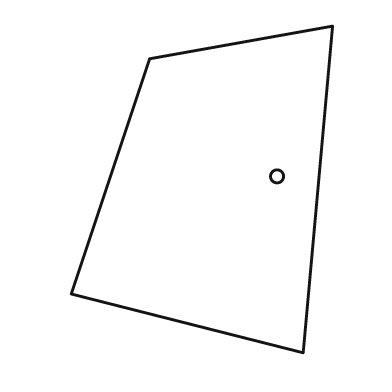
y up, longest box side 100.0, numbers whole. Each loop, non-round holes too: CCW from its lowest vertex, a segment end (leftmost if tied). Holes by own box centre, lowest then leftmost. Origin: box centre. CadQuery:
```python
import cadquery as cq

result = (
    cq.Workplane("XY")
    .moveTo(31.0, -50.0)
    .lineTo(40.0, 50.0)
    .lineTo(-16.0, 40.0)
    .lineTo(-40.0, -32.0)
    .close()
    .moveTo(23.0, 4.0)
    .circle(2.0)
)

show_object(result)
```